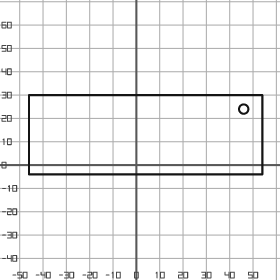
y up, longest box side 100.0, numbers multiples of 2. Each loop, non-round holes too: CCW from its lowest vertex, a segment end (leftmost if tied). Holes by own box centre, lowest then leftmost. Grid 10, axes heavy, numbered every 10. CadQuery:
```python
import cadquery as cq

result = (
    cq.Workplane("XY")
    .moveTo(-46.0, -4.0)
    .lineTo(54.0, -4.0)
    .lineTo(54.0, 30.0)
    .lineTo(-46.0, 30.0)
    .close()
    .moveTo(46.0, 24.0)
    .circle(2.0)
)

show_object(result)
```